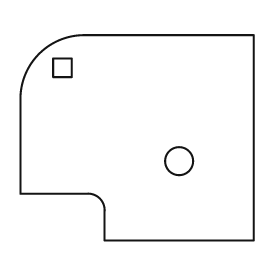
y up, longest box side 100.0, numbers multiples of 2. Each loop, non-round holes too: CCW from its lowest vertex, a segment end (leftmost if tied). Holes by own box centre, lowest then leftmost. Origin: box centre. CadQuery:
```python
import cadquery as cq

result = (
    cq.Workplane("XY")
    .moveTo(-14.0, -44.0)
    .lineTo(50.0, -44.0)
    .lineTo(50.0, 44.0)
    .lineTo(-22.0, 44.0)
    .threePointArc((-42.0, 36.0), (-50.0, 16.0))
    .lineTo(-50.0, -24.0)
    .lineTo(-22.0, -24.0)
    .threePointArc((-16.0, -26.0), (-14.0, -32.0))
    .close()
    .moveTo(18.0, -10.0)
    .circle(6.0)
    .moveTo(-36.0, 26.0)
    .lineTo(-28.0, 26.0)
    .lineTo(-28.0, 34.0)
    .lineTo(-36.0, 34.0)
    .close()
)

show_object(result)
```